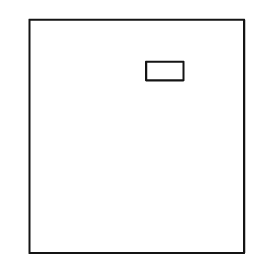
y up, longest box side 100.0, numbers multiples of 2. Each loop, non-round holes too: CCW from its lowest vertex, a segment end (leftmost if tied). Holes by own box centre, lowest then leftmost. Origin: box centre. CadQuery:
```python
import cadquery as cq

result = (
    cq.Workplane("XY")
    .moveTo(-46.0, -50.0)
    .lineTo(46.0, -50.0)
    .lineTo(46.0, 50.0)
    .lineTo(-46.0, 50.0)
    .close()
    .moveTo(4.0, 24.0)
    .lineTo(20.0, 24.0)
    .lineTo(20.0, 32.0)
    .lineTo(4.0, 32.0)
    .close()
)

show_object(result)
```